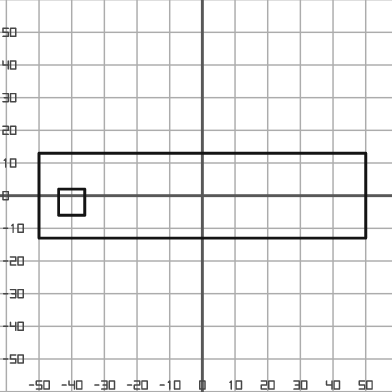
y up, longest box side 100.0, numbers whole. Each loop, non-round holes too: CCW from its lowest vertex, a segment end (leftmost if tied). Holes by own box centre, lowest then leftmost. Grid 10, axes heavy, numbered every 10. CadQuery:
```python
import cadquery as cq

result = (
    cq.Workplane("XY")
    .moveTo(-50.0, -13.0)
    .lineTo(50.0, -13.0)
    .lineTo(50.0, 13.0)
    .lineTo(-50.0, 13.0)
    .close()
    .moveTo(-44.0, -6.0)
    .lineTo(-36.0, -6.0)
    .lineTo(-36.0, 2.0)
    .lineTo(-44.0, 2.0)
    .close()
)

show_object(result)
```